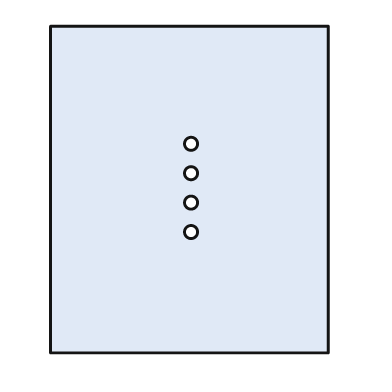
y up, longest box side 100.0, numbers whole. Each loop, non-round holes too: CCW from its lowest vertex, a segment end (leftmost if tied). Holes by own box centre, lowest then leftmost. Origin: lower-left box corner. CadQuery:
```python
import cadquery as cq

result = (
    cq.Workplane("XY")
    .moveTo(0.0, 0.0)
    .lineTo(85.0, 0.0)
    .lineTo(85.0, 100.0)
    .lineTo(0.0, 100.0)
    .close()
    .moveTo(43.0, 37.0)
    .circle(2.0)
    .moveTo(43.0, 46.0)
    .circle(2.0)
    .moveTo(43.0, 55.0)
    .circle(2.0)
    .moveTo(43.0, 64.0)
    .circle(2.0)
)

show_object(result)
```